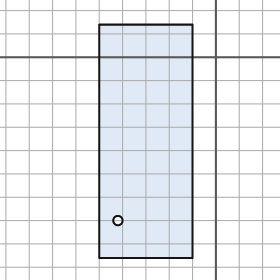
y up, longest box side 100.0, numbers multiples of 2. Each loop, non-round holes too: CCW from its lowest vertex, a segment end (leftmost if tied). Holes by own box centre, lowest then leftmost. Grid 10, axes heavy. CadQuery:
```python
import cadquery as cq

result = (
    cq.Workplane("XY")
    .moveTo(-50.0, -86.0)
    .lineTo(-10.0, -86.0)
    .lineTo(-10.0, 14.0)
    .lineTo(-50.0, 14.0)
    .close()
    .moveTo(-42.0, -70.0)
    .circle(2.0)
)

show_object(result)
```